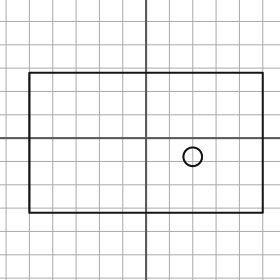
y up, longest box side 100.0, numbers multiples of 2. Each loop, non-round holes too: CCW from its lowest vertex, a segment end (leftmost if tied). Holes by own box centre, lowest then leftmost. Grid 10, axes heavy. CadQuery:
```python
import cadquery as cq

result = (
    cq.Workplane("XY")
    .moveTo(-50.0, -32.0)
    .lineTo(50.0, -32.0)
    .lineTo(50.0, 28.0)
    .lineTo(-50.0, 28.0)
    .close()
    .moveTo(20.0, -8.0)
    .circle(4.0)
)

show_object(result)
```